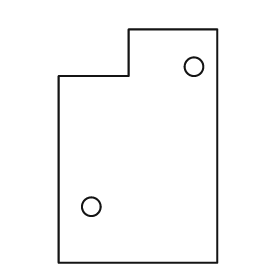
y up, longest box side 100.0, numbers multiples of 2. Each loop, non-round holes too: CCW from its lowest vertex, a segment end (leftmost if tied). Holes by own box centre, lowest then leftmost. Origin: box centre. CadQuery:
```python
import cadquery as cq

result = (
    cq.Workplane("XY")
    .moveTo(-34.0, -50.0)
    .lineTo(34.0, -50.0)
    .lineTo(34.0, 50.0)
    .lineTo(-4.0, 50.0)
    .lineTo(-4.0, 30.0)
    .lineTo(-34.0, 30.0)
    .close()
    .moveTo(-20.0, -26.0)
    .circle(4.0)
    .moveTo(24.0, 34.0)
    .circle(4.0)
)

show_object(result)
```